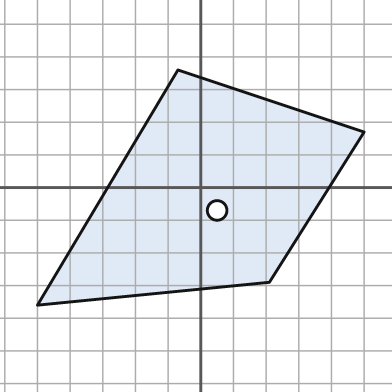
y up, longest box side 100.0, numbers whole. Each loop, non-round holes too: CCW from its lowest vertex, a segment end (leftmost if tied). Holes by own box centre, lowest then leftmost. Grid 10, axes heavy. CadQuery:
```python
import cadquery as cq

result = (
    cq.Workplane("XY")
    .moveTo(-50.0, -36.0)
    .lineTo(21.0, -29.0)
    .lineTo(50.0, 17.0)
    .lineTo(-7.0, 36.0)
    .close()
    .moveTo(5.0, -7.0)
    .circle(3.0)
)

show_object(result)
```